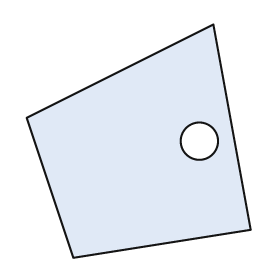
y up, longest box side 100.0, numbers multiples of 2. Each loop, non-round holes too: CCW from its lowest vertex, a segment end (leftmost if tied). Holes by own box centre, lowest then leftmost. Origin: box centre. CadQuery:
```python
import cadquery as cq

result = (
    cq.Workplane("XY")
    .moveTo(-28.0, -50.0)
    .lineTo(48.0, -38.0)
    .lineTo(32.0, 50.0)
    .lineTo(-48.0, 10.0)
    .close()
    .moveTo(26.0, 0.0)
    .circle(8.0)
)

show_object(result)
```